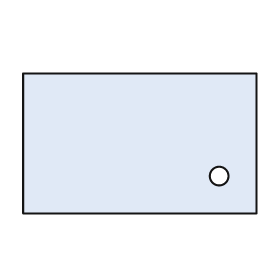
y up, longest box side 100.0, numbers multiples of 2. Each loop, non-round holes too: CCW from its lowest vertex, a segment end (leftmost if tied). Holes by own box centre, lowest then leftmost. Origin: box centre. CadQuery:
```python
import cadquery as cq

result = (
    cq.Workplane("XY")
    .moveTo(-50.0, -30.0)
    .lineTo(50.0, -30.0)
    .lineTo(50.0, 30.0)
    .lineTo(-50.0, 30.0)
    .close()
    .moveTo(34.0, -14.0)
    .circle(4.0)
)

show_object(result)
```